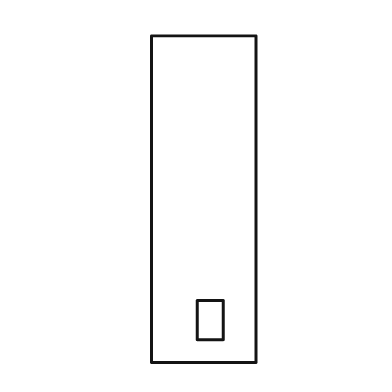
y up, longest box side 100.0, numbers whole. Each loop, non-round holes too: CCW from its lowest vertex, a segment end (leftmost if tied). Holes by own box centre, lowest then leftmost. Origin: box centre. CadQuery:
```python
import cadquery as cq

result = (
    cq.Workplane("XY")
    .moveTo(-16.0, -50.0)
    .lineTo(16.0, -50.0)
    .lineTo(16.0, 50.0)
    .lineTo(-16.0, 50.0)
    .close()
    .moveTo(-2.0, -43.0)
    .lineTo(6.0, -43.0)
    .lineTo(6.0, -31.0)
    .lineTo(-2.0, -31.0)
    .close()
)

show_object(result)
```